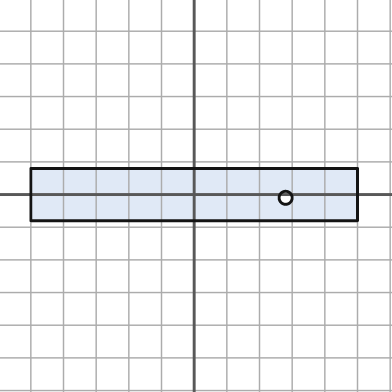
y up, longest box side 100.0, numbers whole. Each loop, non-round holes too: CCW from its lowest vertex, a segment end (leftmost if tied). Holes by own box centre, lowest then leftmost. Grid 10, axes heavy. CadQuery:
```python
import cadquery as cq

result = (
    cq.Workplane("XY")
    .moveTo(-50.0, -8.0)
    .lineTo(50.0, -8.0)
    .lineTo(50.0, 8.0)
    .lineTo(-50.0, 8.0)
    .close()
    .moveTo(28.0, -1.0)
    .circle(2.0)
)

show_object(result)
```